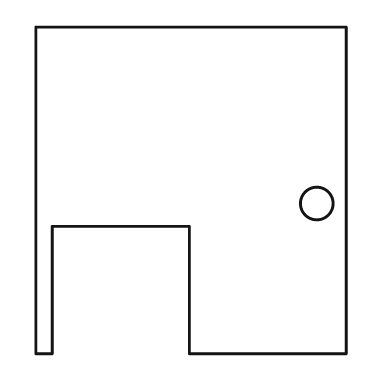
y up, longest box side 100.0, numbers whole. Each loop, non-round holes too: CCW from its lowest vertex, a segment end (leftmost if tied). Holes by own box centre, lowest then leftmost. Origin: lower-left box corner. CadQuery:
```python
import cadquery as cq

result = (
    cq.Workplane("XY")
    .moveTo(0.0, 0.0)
    .lineTo(5.0, 0.0)
    .lineTo(5.0, 39.0)
    .lineTo(47.0, 39.0)
    .lineTo(47.0, 0.0)
    .lineTo(95.0, 0.0)
    .lineTo(95.0, 100.0)
    .lineTo(0.0, 100.0)
    .close()
    .moveTo(86.0, 46.0)
    .circle(5.0)
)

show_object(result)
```